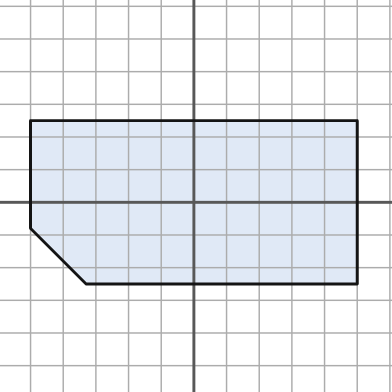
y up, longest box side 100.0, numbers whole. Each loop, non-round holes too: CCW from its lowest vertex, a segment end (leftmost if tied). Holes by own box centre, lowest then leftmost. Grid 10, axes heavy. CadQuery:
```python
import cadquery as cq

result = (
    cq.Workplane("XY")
    .moveTo(-33.0, -25.0)
    .lineTo(50.0, -25.0)
    .lineTo(50.0, 25.0)
    .lineTo(-50.0, 25.0)
    .lineTo(-50.0, -8.0)
    .close()
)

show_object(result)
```